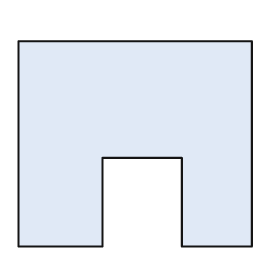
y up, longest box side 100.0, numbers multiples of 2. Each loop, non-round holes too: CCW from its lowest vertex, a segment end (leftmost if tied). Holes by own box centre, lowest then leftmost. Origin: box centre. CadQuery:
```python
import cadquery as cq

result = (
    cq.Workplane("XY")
    .moveTo(-50.0, -44.0)
    .lineTo(-14.0, -44.0)
    .lineTo(-14.0, -6.0)
    .lineTo(20.0, -6.0)
    .lineTo(20.0, -44.0)
    .lineTo(50.0, -44.0)
    .lineTo(50.0, 44.0)
    .lineTo(-50.0, 44.0)
    .close()
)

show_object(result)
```